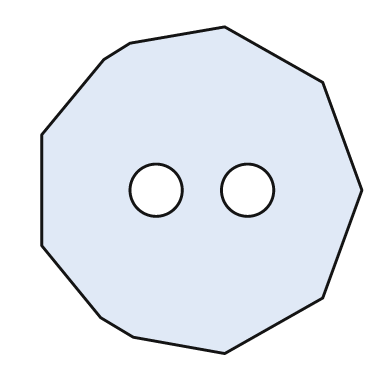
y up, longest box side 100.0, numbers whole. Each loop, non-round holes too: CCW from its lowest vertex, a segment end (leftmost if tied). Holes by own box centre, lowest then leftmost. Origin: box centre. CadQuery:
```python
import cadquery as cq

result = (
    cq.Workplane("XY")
    .moveTo(7.0, -50.0)
    .lineTo(37.0, -33.0)
    .lineTo(49.0, 0.0)
    .lineTo(37.0, 33.0)
    .lineTo(7.0, 50.0)
    .lineTo(-22.0, 45.0)
    .lineTo(-30.0, 40.0)
    .lineTo(-49.0, 17.0)
    .lineTo(-49.0, -17.0)
    .lineTo(-31.0, -39.0)
    .lineTo(-21.0, -45.0)
    .close()
    .moveTo(-14.0, 0.0)
    .circle(8.0)
    .moveTo(14.0, 0.0)
    .circle(8.0)
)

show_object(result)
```